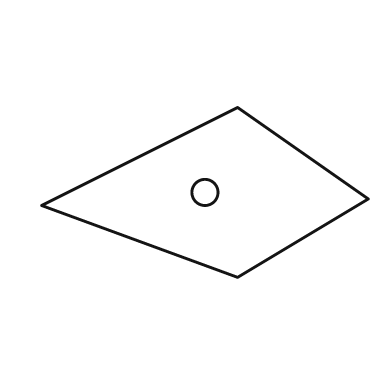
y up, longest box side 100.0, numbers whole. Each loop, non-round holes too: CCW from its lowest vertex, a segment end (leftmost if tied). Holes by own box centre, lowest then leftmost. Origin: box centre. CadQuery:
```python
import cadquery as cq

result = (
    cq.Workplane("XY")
    .moveTo(10.0, -26.0)
    .lineTo(50.0, -2.0)
    .lineTo(10.0, 26.0)
    .lineTo(-50.0, -4.0)
    .close()
    .moveTo(0.0, 0.0)
    .circle(4.0)
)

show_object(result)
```